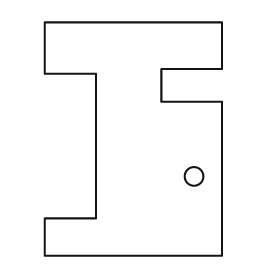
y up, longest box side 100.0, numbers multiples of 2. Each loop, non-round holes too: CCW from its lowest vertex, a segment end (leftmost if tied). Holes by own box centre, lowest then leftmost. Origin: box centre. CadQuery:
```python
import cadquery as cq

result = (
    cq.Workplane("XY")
    .moveTo(-38.0, -50.0)
    .lineTo(38.0, -50.0)
    .lineTo(38.0, 16.0)
    .lineTo(12.0, 16.0)
    .lineTo(12.0, 30.0)
    .lineTo(38.0, 30.0)
    .lineTo(38.0, 50.0)
    .lineTo(-38.0, 50.0)
    .lineTo(-38.0, 28.0)
    .lineTo(-16.0, 28.0)
    .lineTo(-16.0, -34.0)
    .lineTo(-38.0, -34.0)
    .close()
    .moveTo(26.0, -16.0)
    .circle(4.0)
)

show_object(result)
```